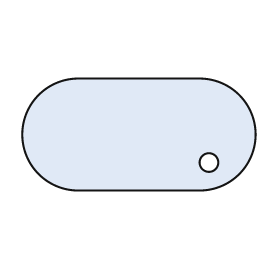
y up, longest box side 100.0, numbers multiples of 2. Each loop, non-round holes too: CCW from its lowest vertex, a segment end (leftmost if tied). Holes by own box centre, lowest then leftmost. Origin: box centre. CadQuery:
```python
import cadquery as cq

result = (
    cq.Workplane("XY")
    .moveTo(-26.0, -24.0)
    .lineTo(26.0, -24.0)
    .threePointArc((50.0, 0.0), (26.0, 24.0))
    .lineTo(-26.0, 24.0)
    .threePointArc((-50.0, 0.0), (-26.0, -24.0))
    .close()
    .moveTo(30.0, -12.0)
    .circle(4.0)
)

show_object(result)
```